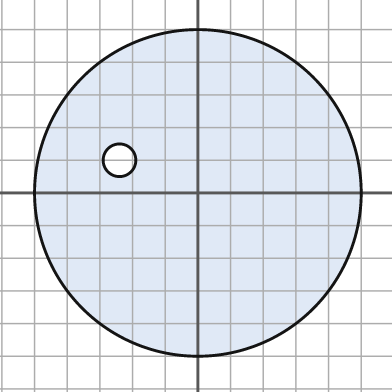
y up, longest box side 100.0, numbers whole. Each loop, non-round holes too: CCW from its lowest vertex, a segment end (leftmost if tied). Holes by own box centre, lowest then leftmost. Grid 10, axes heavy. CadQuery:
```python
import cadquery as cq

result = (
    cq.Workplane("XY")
    .moveTo(0.0, 0.0)
    .circle(50.0)
    .moveTo(-24.0, 10.0)
    .circle(5.0)
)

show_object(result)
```